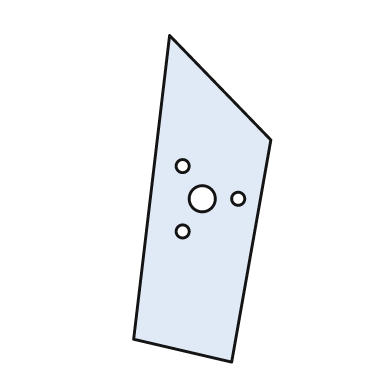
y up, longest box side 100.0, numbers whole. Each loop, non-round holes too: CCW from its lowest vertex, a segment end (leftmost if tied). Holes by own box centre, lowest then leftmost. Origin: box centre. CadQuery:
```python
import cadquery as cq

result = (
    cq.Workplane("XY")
    .moveTo(9.0, -50.0)
    .lineTo(21.0, 18.0)
    .lineTo(-10.0, 50.0)
    .lineTo(-21.0, -43.0)
    .close()
    .moveTo(-6.0, -10.0)
    .circle(2.0)
    .moveTo(0.0, 0.0)
    .circle(4.0)
    .moveTo(11.0, 0.0)
    .circle(2.0)
    .moveTo(-6.0, 10.0)
    .circle(2.0)
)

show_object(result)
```